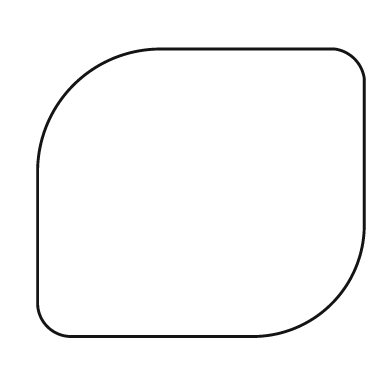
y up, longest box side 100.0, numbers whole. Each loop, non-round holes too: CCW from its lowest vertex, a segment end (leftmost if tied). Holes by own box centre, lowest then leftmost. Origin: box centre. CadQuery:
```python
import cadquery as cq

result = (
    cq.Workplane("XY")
    .moveTo(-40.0, -44.0)
    .lineTo(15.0, -44.0)
    .threePointArc((40.0, -34.0), (50.0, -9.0))
    .lineTo(50.0, 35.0)
    .threePointArc((47.0, 41.0), (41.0, 44.0))
    .lineTo(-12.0, 44.0)
    .threePointArc((-39.0, 33.0), (-50.0, 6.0))
    .lineTo(-50.0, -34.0)
    .threePointArc((-47.0, -41.0), (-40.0, -44.0))
    .close()
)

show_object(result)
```